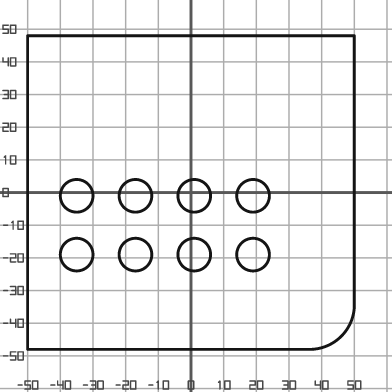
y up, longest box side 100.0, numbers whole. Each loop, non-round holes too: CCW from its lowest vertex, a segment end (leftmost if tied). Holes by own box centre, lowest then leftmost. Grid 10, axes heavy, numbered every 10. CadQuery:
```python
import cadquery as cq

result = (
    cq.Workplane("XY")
    .moveTo(-50.0, -48.0)
    .lineTo(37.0, -48.0)
    .threePointArc((46.0, -44.0), (50.0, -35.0))
    .lineTo(50.0, 48.0)
    .lineTo(-50.0, 48.0)
    .close()
    .moveTo(-35.0, -19.0)
    .circle(5.0)
    .moveTo(-17.0, -19.0)
    .circle(5.0)
    .moveTo(1.0, -19.0)
    .circle(5.0)
    .moveTo(19.0, -19.0)
    .circle(5.0)
    .moveTo(-35.0, -1.0)
    .circle(5.0)
    .moveTo(-17.0, -1.0)
    .circle(5.0)
    .moveTo(1.0, -1.0)
    .circle(5.0)
    .moveTo(19.0, -1.0)
    .circle(5.0)
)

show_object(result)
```